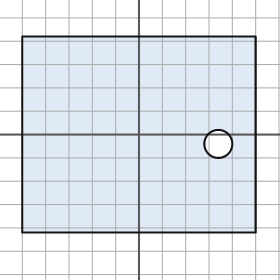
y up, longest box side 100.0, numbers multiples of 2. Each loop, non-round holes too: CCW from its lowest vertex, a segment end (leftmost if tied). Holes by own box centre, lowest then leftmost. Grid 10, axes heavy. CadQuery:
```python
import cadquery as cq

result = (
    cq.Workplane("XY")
    .moveTo(-50.0, -42.0)
    .lineTo(50.0, -42.0)
    .lineTo(50.0, 42.0)
    .lineTo(-50.0, 42.0)
    .close()
    .moveTo(34.0, -4.0)
    .circle(6.0)
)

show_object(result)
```